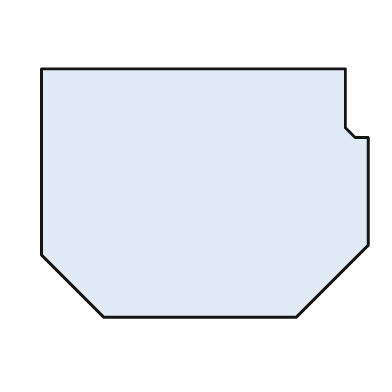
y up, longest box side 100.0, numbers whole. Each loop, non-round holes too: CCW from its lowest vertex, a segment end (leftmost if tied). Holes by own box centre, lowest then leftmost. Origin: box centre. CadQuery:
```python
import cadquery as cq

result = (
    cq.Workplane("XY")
    .moveTo(-31.0, -38.0)
    .lineTo(28.0, -38.0)
    .lineTo(50.0, -16.0)
    .lineTo(50.0, 17.0)
    .lineTo(46.0, 17.0)
    .lineTo(43.0, 20.0)
    .lineTo(43.0, 38.0)
    .lineTo(-50.0, 38.0)
    .lineTo(-50.0, -19.0)
    .close()
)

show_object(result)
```